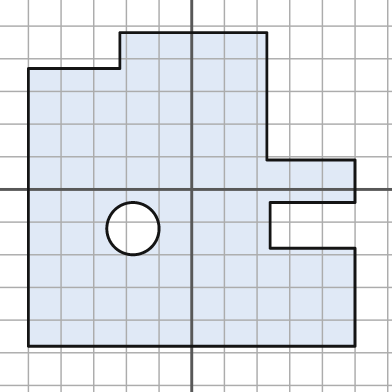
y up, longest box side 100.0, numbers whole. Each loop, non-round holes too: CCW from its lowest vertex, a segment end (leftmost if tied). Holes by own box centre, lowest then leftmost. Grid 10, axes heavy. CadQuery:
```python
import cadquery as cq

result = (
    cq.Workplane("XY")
    .moveTo(-50.0, -48.0)
    .lineTo(50.0, -48.0)
    .lineTo(50.0, -18.0)
    .lineTo(24.0, -18.0)
    .lineTo(24.0, -4.0)
    .lineTo(50.0, -4.0)
    .lineTo(50.0, 9.0)
    .lineTo(23.0, 9.0)
    .lineTo(23.0, 48.0)
    .lineTo(-22.0, 48.0)
    .lineTo(-22.0, 37.0)
    .lineTo(-50.0, 37.0)
    .close()
    .moveTo(-18.0, -12.0)
    .circle(8.0)
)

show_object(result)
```